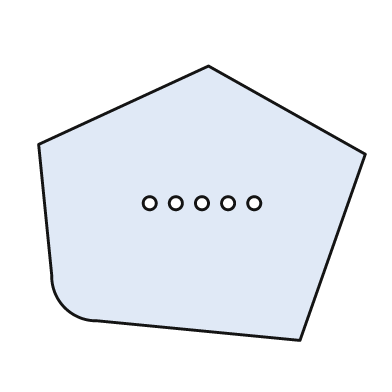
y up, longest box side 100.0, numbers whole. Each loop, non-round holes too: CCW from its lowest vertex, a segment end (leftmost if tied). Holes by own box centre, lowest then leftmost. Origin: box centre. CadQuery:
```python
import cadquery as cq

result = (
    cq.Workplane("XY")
    .moveTo(30.0, -42.0)
    .lineTo(50.0, 15.0)
    .lineTo(2.0, 42.0)
    .lineTo(-50.0, 18.0)
    .lineTo(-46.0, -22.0)
    .threePointArc((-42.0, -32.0), (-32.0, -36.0))
    .close()
    .moveTo(-16.0, 0.0)
    .circle(2.0)
    .moveTo(-8.0, 0.0)
    .circle(2.0)
    .moveTo(0.0, 0.0)
    .circle(2.0)
    .moveTo(8.0, 0.0)
    .circle(2.0)
    .moveTo(16.0, 0.0)
    .circle(2.0)
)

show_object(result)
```